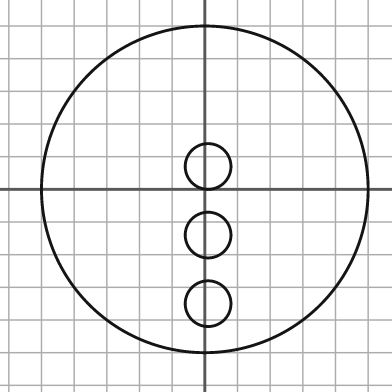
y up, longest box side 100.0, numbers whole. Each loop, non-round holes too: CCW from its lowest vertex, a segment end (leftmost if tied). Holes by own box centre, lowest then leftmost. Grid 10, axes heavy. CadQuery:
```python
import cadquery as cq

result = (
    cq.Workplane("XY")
    .moveTo(0.0, 0.0)
    .circle(50.0)
    .moveTo(1.0, -35.0)
    .circle(7.0)
    .moveTo(1.0, -14.0)
    .circle(7.0)
    .moveTo(1.0, 7.0)
    .circle(7.0)
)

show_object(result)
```